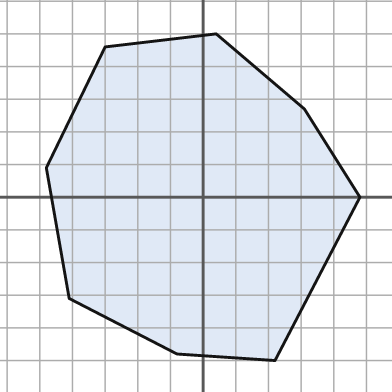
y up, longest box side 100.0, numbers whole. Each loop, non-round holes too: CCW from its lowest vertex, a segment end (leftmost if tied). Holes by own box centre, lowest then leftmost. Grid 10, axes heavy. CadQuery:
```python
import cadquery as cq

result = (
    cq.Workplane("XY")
    .moveTo(22.0, -50.0)
    .lineTo(48.0, 0.0)
    .lineTo(31.0, 27.0)
    .lineTo(4.0, 50.0)
    .lineTo(-30.0, 46.0)
    .lineTo(-48.0, 9.0)
    .lineTo(-41.0, -31.0)
    .lineTo(-8.0, -48.0)
    .close()
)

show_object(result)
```